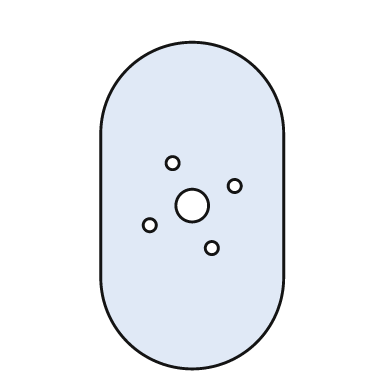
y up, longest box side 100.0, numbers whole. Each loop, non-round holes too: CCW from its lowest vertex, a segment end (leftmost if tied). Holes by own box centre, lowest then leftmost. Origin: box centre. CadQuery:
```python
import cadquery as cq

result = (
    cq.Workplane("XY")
    .moveTo(-28.0, -22.0)
    .threePointArc((0.0, -50.0), (28.0, -22.0))
    .lineTo(28.0, 22.0)
    .threePointArc((0.0, 50.0), (-28.0, 22.0))
    .close()
    .moveTo(6.0, -13.0)
    .circle(2.0)
    .moveTo(-13.0, -6.0)
    .circle(2.0)
    .moveTo(0.0, 0.0)
    .circle(5.0)
    .moveTo(13.0, 6.0)
    .circle(2.0)
    .moveTo(-6.0, 13.0)
    .circle(2.0)
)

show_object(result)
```